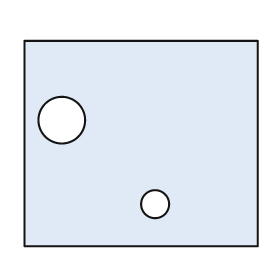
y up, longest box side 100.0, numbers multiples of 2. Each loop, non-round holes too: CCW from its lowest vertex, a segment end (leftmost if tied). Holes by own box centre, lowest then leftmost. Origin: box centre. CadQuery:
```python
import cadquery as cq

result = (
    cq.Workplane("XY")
    .moveTo(-50.0, -44.0)
    .lineTo(50.0, -44.0)
    .lineTo(50.0, 44.0)
    .lineTo(-50.0, 44.0)
    .close()
    .moveTo(6.0, -26.0)
    .circle(6.0)
    .moveTo(-34.0, 10.0)
    .circle(10.0)
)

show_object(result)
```